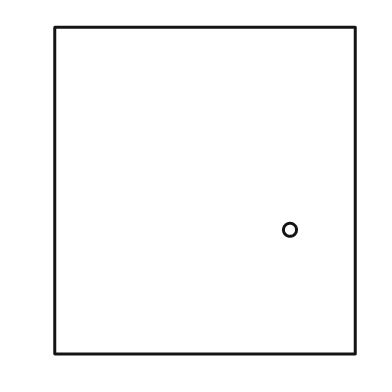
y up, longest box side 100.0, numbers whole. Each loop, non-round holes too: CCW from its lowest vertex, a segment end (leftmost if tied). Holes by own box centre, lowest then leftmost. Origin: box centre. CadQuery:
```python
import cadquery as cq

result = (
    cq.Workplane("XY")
    .moveTo(-46.0, -50.0)
    .lineTo(46.0, -50.0)
    .lineTo(46.0, 50.0)
    .lineTo(-46.0, 50.0)
    .close()
    .moveTo(26.0, -12.0)
    .circle(2.0)
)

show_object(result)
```